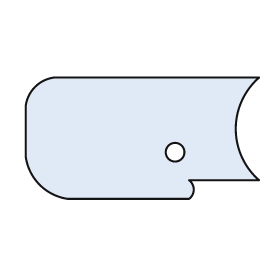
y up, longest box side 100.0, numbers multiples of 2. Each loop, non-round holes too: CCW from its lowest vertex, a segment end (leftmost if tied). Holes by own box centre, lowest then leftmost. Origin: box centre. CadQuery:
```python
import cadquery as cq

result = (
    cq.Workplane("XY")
    .moveTo(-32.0, -26.0)
    .lineTo(20.0, -26.0)
    .threePointArc((22.0, -22.0), (20.0, -18.0))
    .lineTo(50.0, -18.0)
    .threePointArc((40.0, 4.0), (50.0, 26.0))
    .lineTo(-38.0, 26.0)
    .threePointArc((-46.0, 22.0), (-50.0, 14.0))
    .lineTo(-50.0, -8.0)
    .threePointArc((-44.0, -20.0), (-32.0, -26.0))
    .close()
    .moveTo(14.0, -6.0)
    .circle(4.0)
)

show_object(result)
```